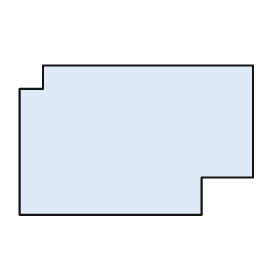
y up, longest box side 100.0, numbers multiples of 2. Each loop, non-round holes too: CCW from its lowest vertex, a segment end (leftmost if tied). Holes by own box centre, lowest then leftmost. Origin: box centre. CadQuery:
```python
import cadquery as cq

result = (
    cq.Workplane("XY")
    .moveTo(-50.0, -32.0)
    .lineTo(28.0, -32.0)
    .lineTo(28.0, -16.0)
    .lineTo(50.0, -16.0)
    .lineTo(50.0, 32.0)
    .lineTo(-40.0, 32.0)
    .lineTo(-40.0, 22.0)
    .lineTo(-50.0, 22.0)
    .close()
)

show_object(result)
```